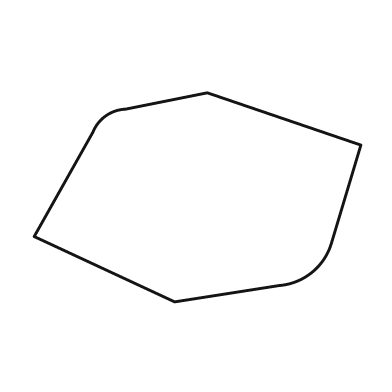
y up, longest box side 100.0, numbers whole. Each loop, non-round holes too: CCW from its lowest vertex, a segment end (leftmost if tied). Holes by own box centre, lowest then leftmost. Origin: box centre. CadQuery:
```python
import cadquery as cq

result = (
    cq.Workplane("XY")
    .moveTo(-7.0, -32.0)
    .lineTo(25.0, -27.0)
    .threePointArc((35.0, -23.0), (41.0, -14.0))
    .lineTo(50.0, 16.0)
    .lineTo(3.0, 32.0)
    .lineTo(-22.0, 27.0)
    .threePointArc((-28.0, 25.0), (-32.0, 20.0))
    .lineTo(-50.0, -12.0)
    .close()
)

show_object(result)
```